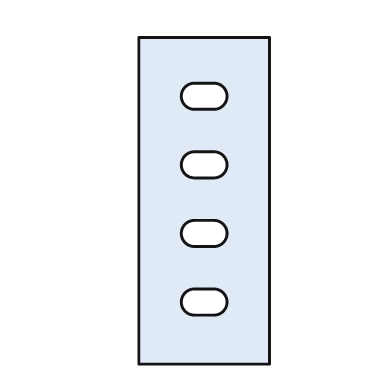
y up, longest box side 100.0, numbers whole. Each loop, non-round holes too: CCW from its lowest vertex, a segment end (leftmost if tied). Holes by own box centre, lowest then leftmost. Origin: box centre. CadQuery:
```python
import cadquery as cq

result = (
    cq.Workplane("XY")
    .moveTo(-20.0, -50.0)
    .lineTo(20.0, -50.0)
    .lineTo(20.0, 50.0)
    .lineTo(-20.0, 50.0)
    .close()
    .moveTo(-3.0, -35.0)
    .lineTo(3.0, -35.0)
    .threePointArc((7.0, -31.0), (3.0, -27.0))
    .lineTo(-3.0, -27.0)
    .threePointArc((-7.0, -31.0), (-3.0, -35.0))
    .close()
    .moveTo(-3.0, -14.0)
    .lineTo(3.0, -14.0)
    .threePointArc((7.0, -10.0), (3.0, -6.0))
    .lineTo(-3.0, -6.0)
    .threePointArc((-7.0, -10.0), (-3.0, -14.0))
    .close()
    .moveTo(-3.0, 7.0)
    .lineTo(3.0, 7.0)
    .threePointArc((7.0, 11.0), (3.0, 15.0))
    .lineTo(-3.0, 15.0)
    .threePointArc((-7.0, 11.0), (-3.0, 7.0))
    .close()
    .moveTo(-3.0, 28.0)
    .lineTo(3.0, 28.0)
    .threePointArc((7.0, 32.0), (3.0, 36.0))
    .lineTo(-3.0, 36.0)
    .threePointArc((-7.0, 32.0), (-3.0, 28.0))
    .close()
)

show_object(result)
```